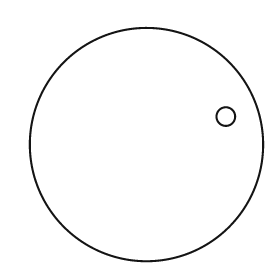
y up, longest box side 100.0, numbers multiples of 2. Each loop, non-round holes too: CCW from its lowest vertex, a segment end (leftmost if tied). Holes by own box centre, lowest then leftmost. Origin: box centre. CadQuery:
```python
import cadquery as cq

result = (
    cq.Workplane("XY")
    .moveTo(0.0, 0.0)
    .circle(50.0)
    .moveTo(34.0, 12.0)
    .circle(4.0)
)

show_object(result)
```